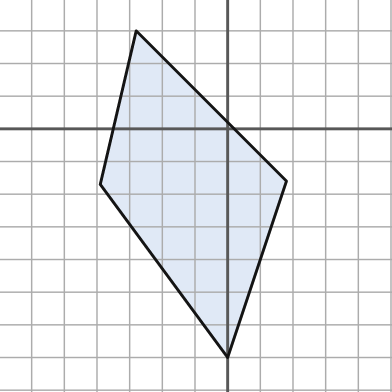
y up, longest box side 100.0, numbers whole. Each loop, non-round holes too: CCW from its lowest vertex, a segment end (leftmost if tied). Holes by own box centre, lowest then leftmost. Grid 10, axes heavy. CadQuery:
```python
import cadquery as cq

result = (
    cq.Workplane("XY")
    .moveTo(0.0, -70.0)
    .lineTo(18.0, -16.0)
    .lineTo(-28.0, 30.0)
    .lineTo(-39.0, -17.0)
    .close()
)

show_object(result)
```